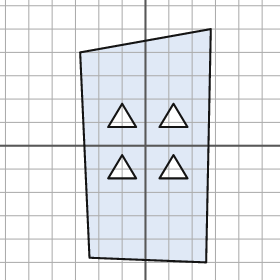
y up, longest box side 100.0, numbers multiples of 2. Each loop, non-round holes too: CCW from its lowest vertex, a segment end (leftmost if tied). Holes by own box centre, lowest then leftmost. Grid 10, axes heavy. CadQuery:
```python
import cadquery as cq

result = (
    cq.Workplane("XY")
    .moveTo(26.0, -50.0)
    .lineTo(28.0, 50.0)
    .lineTo(-28.0, 40.0)
    .lineTo(-24.0, -48.0)
    .close()
    .moveTo(-16.0, -14.0)
    .lineTo(-4.0, -14.0)
    .lineTo(-10.0, -4.0)
    .close()
    .moveTo(6.0, -14.0)
    .lineTo(18.0, -14.0)
    .lineTo(12.0, -4.0)
    .close()
    .moveTo(-16.0, 8.0)
    .lineTo(-4.0, 8.0)
    .lineTo(-10.0, 18.0)
    .close()
    .moveTo(6.0, 8.0)
    .lineTo(18.0, 8.0)
    .lineTo(12.0, 18.0)
    .close()
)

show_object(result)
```